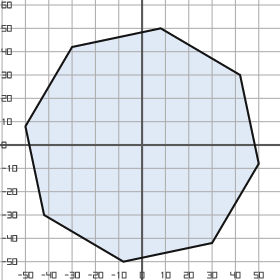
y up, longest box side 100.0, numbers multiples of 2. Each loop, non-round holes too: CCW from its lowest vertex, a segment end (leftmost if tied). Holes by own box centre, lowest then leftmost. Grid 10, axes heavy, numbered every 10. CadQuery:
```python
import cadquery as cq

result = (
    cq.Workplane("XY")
    .moveTo(-8.0, -50.0)
    .lineTo(30.0, -42.0)
    .lineTo(50.0, -8.0)
    .lineTo(42.0, 30.0)
    .lineTo(8.0, 50.0)
    .lineTo(-30.0, 42.0)
    .lineTo(-50.0, 8.0)
    .lineTo(-42.0, -30.0)
    .close()
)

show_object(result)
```